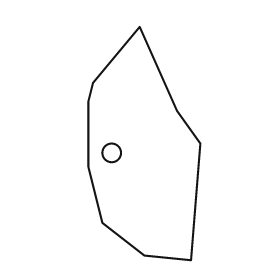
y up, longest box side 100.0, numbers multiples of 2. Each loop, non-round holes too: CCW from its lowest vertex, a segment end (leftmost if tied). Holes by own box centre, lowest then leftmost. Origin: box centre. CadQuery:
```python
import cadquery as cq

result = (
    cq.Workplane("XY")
    .moveTo(20.0, -50.0)
    .lineTo(24.0, 0.0)
    .lineTo(14.0, 14.0)
    .lineTo(-2.0, 50.0)
    .lineTo(-22.0, 26.0)
    .lineTo(-24.0, 18.0)
    .lineTo(-24.0, -10.0)
    .lineTo(-18.0, -34.0)
    .lineTo(0.0, -48.0)
    .close()
    .moveTo(-14.0, -4.0)
    .circle(4.0)
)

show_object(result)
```